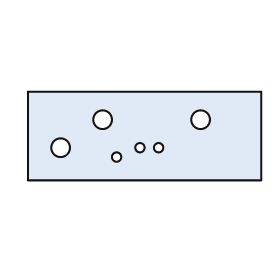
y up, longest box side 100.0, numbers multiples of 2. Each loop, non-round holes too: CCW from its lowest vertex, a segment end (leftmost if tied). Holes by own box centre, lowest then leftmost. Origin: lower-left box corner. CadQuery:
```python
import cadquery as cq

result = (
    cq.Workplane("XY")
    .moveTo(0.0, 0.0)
    .lineTo(100.0, 0.0)
    .lineTo(100.0, 38.0)
    .lineTo(0.0, 38.0)
    .close()
    .moveTo(38.0, 10.0)
    .circle(2.0)
    .moveTo(14.0, 14.0)
    .circle(4.0)
    .moveTo(48.0, 14.0)
    .circle(2.0)
    .moveTo(56.0, 14.0)
    .circle(2.0)
    .moveTo(32.0, 26.0)
    .circle(4.0)
    .moveTo(74.0, 26.0)
    .circle(4.0)
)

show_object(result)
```